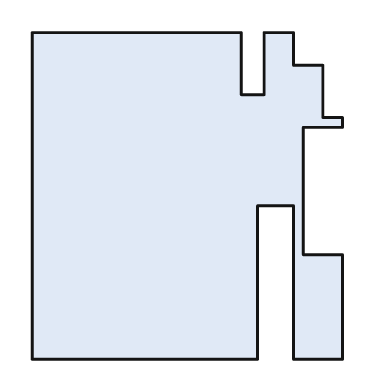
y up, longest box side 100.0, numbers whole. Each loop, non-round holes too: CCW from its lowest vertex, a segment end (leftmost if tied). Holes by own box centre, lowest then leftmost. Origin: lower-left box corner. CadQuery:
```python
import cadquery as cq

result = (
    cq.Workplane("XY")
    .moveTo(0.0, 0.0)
    .lineTo(69.0, 0.0)
    .lineTo(69.0, 47.0)
    .lineTo(80.0, 47.0)
    .lineTo(80.0, 0.0)
    .lineTo(95.0, 0.0)
    .lineTo(95.0, 32.0)
    .lineTo(83.0, 32.0)
    .lineTo(83.0, 71.0)
    .lineTo(95.0, 71.0)
    .lineTo(95.0, 74.0)
    .lineTo(89.0, 74.0)
    .lineTo(89.0, 90.0)
    .lineTo(80.0, 90.0)
    .lineTo(80.0, 100.0)
    .lineTo(71.0, 100.0)
    .lineTo(71.0, 81.0)
    .lineTo(64.0, 81.0)
    .lineTo(64.0, 100.0)
    .lineTo(0.0, 100.0)
    .close()
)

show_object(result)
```